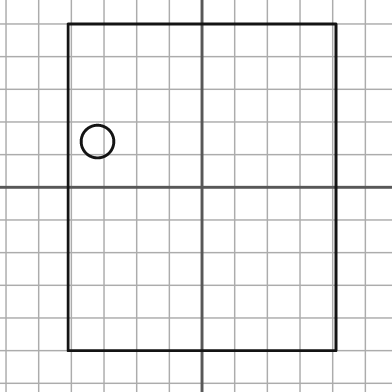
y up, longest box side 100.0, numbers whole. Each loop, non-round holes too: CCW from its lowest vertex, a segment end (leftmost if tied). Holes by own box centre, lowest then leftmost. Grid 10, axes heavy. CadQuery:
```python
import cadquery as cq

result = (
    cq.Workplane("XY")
    .moveTo(-41.0, -50.0)
    .lineTo(41.0, -50.0)
    .lineTo(41.0, 50.0)
    .lineTo(-41.0, 50.0)
    .close()
    .moveTo(-32.0, 14.0)
    .circle(5.0)
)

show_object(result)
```